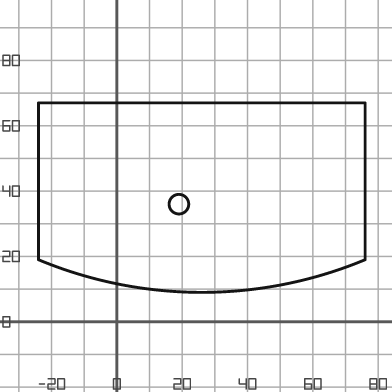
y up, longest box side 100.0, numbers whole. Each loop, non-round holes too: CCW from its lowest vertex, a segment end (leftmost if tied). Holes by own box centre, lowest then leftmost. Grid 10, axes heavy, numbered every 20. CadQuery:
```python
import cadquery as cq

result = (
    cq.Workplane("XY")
    .moveTo(-24.0, 19.0)
    .threePointArc((26.0, 9.0), (76.0, 19.0))
    .lineTo(76.0, 67.0)
    .lineTo(-24.0, 67.0)
    .close()
    .moveTo(19.0, 36.0)
    .circle(3.0)
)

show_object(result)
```